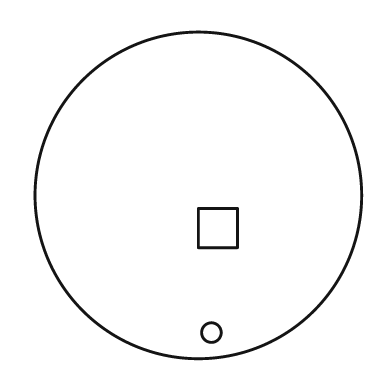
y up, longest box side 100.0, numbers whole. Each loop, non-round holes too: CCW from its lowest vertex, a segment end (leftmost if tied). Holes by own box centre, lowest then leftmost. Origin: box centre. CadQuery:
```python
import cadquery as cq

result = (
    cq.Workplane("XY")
    .moveTo(0.0, 0.0)
    .circle(50.0)
    .moveTo(4.0, -42.0)
    .circle(3.0)
    .moveTo(0.0, -16.0)
    .lineTo(12.0, -16.0)
    .lineTo(12.0, -4.0)
    .lineTo(0.0, -4.0)
    .close()
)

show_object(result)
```